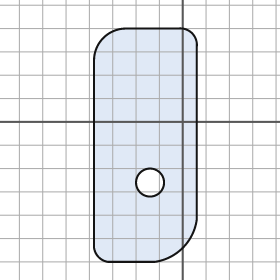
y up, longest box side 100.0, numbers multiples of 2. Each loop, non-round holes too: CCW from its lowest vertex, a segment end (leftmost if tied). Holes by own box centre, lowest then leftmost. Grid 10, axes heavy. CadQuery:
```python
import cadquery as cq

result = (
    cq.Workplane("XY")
    .moveTo(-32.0, -60.0)
    .lineTo(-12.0, -60.0)
    .threePointArc((0.0, -54.0), (6.0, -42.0))
    .lineTo(6.0, 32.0)
    .threePointArc((4.0, 38.0), (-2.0, 40.0))
    .lineTo(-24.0, 40.0)
    .threePointArc((-34.0, 36.0), (-38.0, 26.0))
    .lineTo(-38.0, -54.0)
    .threePointArc((-36.0, -58.0), (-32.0, -60.0))
    .close()
    .moveTo(-14.0, -26.0)
    .circle(6.0)
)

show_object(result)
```